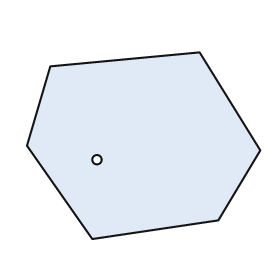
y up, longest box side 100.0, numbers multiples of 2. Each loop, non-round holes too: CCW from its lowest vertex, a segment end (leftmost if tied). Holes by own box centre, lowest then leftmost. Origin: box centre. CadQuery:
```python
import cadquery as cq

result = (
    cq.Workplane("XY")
    .moveTo(-22.0, -40.0)
    .lineTo(32.0, -32.0)
    .lineTo(50.0, -2.0)
    .lineTo(24.0, 40.0)
    .lineTo(-40.0, 34.0)
    .lineTo(-50.0, 0.0)
    .close()
    .moveTo(-20.0, -6.0)
    .circle(2.0)
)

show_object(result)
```